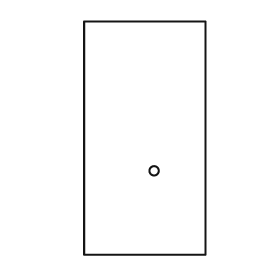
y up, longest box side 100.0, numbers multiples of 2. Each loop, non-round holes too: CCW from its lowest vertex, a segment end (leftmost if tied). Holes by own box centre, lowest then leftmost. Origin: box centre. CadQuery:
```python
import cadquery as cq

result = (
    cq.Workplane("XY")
    .moveTo(-26.0, -50.0)
    .lineTo(26.0, -50.0)
    .lineTo(26.0, 50.0)
    .lineTo(-26.0, 50.0)
    .close()
    .moveTo(4.0, -14.0)
    .circle(2.0)
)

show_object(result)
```